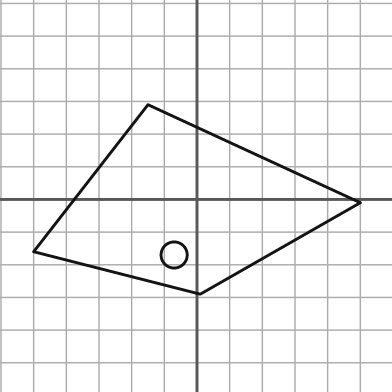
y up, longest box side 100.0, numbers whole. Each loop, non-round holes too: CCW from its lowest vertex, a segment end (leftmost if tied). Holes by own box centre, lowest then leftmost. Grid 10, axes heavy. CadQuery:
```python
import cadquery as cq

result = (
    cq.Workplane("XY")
    .moveTo(1.0, -29.0)
    .lineTo(50.0, -1.0)
    .lineTo(-15.0, 29.0)
    .lineTo(-50.0, -16.0)
    .close()
    .moveTo(-7.0, -17.0)
    .circle(4.0)
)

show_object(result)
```